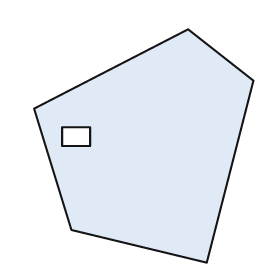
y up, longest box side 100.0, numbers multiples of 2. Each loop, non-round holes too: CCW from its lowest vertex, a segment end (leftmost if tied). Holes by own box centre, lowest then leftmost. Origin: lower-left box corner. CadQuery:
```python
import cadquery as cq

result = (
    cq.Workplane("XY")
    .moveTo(74.0, 0.0)
    .lineTo(94.0, 78.0)
    .lineTo(66.0, 100.0)
    .lineTo(0.0, 66.0)
    .lineTo(16.0, 14.0)
    .close()
    .moveTo(12.0, 50.0)
    .lineTo(24.0, 50.0)
    .lineTo(24.0, 58.0)
    .lineTo(12.0, 58.0)
    .close()
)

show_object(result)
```